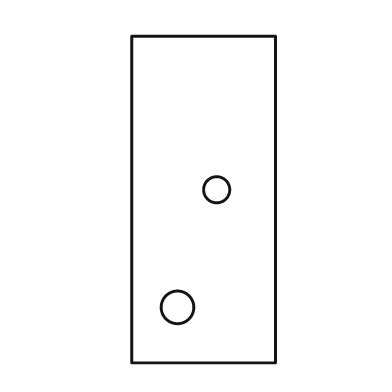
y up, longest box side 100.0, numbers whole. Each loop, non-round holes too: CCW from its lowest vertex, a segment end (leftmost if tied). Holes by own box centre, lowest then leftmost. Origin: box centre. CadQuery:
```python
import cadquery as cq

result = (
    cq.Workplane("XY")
    .moveTo(-22.0, -50.0)
    .lineTo(22.0, -50.0)
    .lineTo(22.0, 50.0)
    .lineTo(-22.0, 50.0)
    .close()
    .moveTo(-8.0, -33.0)
    .circle(5.0)
    .moveTo(4.0, 3.0)
    .circle(4.0)
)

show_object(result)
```